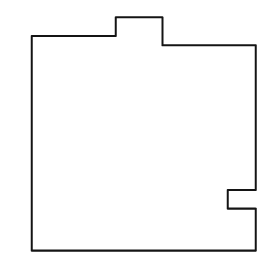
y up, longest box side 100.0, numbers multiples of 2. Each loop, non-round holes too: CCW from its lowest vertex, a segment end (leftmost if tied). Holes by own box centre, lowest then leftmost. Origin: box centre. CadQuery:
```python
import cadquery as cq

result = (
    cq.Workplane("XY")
    .moveTo(-48.0, -50.0)
    .lineTo(48.0, -50.0)
    .lineTo(48.0, -32.0)
    .lineTo(36.0, -32.0)
    .lineTo(36.0, -24.0)
    .lineTo(48.0, -24.0)
    .lineTo(48.0, 38.0)
    .lineTo(8.0, 38.0)
    .lineTo(8.0, 50.0)
    .lineTo(-12.0, 50.0)
    .lineTo(-12.0, 42.0)
    .lineTo(-48.0, 42.0)
    .close()
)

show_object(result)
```